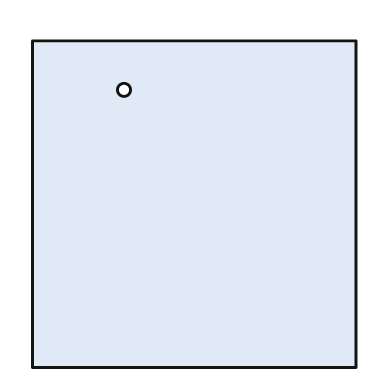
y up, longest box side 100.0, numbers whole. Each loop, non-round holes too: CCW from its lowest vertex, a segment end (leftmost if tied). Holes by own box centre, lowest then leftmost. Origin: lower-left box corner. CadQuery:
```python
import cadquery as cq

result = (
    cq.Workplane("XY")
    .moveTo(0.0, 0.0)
    .lineTo(99.0, 0.0)
    .lineTo(99.0, 100.0)
    .lineTo(0.0, 100.0)
    .close()
    .moveTo(28.0, 85.0)
    .circle(2.0)
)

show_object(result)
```